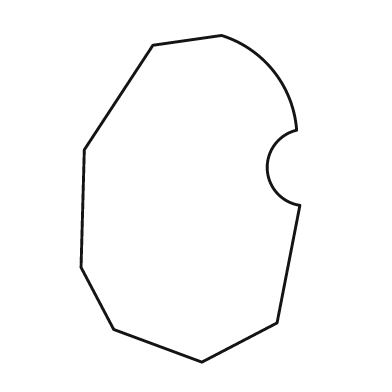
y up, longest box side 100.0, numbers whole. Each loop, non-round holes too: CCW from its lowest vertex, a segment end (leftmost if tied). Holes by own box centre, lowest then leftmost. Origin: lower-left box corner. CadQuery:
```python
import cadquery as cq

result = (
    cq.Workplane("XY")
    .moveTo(37.0, 0.0)
    .lineTo(60.0, 12.0)
    .lineTo(67.0, 48.0)
    .threePointArc((57.0, 59.0), (66.0, 71.0))
    .threePointArc((59.0, 89.0), (43.0, 100.0))
    .lineTo(22.0, 97.0)
    .lineTo(1.0, 65.0)
    .lineTo(0.0, 29.0)
    .lineTo(10.0, 10.0)
    .close()
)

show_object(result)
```